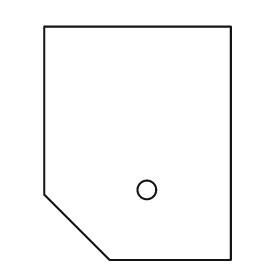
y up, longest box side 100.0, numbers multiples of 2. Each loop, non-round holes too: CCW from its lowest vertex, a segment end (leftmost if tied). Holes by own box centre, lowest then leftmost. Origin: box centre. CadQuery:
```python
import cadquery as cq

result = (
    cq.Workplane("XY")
    .moveTo(-12.0, -50.0)
    .lineTo(40.0, -50.0)
    .lineTo(40.0, 50.0)
    .lineTo(-40.0, 50.0)
    .lineTo(-40.0, -22.0)
    .close()
    .moveTo(4.0, -20.0)
    .circle(4.0)
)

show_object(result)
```